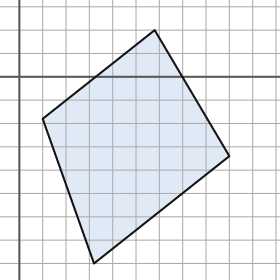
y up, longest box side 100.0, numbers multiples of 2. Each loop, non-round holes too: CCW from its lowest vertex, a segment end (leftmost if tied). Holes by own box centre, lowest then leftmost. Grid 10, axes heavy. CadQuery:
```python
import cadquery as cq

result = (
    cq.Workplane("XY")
    .moveTo(32.0, -80.0)
    .lineTo(90.0, -34.0)
    .lineTo(58.0, 20.0)
    .lineTo(10.0, -18.0)
    .close()
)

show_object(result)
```